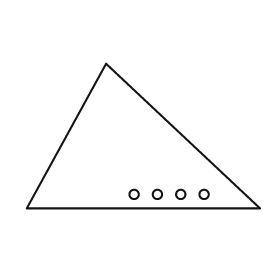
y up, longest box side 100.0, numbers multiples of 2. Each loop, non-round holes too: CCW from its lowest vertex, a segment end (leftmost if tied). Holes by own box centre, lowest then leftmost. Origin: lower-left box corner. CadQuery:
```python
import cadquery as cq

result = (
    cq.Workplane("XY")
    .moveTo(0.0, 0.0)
    .lineTo(100.0, 0.0)
    .lineTo(34.0, 62.0)
    .close()
    .moveTo(46.0, 6.0)
    .circle(2.0)
    .moveTo(56.0, 6.0)
    .circle(2.0)
    .moveTo(66.0, 6.0)
    .circle(2.0)
    .moveTo(76.0, 6.0)
    .circle(2.0)
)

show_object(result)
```